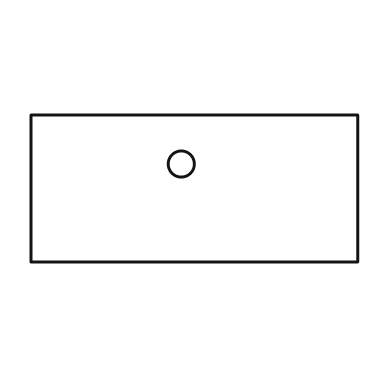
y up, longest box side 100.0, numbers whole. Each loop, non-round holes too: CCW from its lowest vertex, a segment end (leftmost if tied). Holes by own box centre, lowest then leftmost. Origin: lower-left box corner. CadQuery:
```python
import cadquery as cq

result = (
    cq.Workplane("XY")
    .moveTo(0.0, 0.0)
    .lineTo(100.0, 0.0)
    .lineTo(100.0, 45.0)
    .lineTo(0.0, 45.0)
    .close()
    .moveTo(46.0, 30.0)
    .circle(4.0)
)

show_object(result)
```